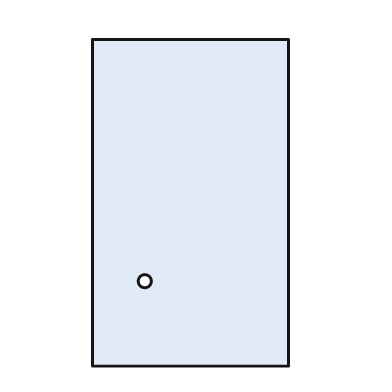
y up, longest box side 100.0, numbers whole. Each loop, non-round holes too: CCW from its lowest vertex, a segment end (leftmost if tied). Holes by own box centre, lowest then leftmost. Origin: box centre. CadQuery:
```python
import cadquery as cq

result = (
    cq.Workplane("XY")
    .moveTo(-30.0, -50.0)
    .lineTo(30.0, -50.0)
    .lineTo(30.0, 50.0)
    .lineTo(-30.0, 50.0)
    .close()
    .moveTo(-14.0, -24.0)
    .circle(2.0)
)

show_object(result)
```